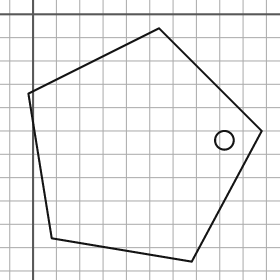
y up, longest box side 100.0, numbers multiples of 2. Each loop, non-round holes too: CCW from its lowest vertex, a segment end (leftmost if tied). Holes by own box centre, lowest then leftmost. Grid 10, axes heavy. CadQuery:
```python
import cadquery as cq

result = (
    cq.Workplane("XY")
    .moveTo(68.0, -106.0)
    .lineTo(98.0, -50.0)
    .lineTo(54.0, -6.0)
    .lineTo(-2.0, -34.0)
    .lineTo(8.0, -96.0)
    .close()
    .moveTo(82.0, -54.0)
    .circle(4.0)
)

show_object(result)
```